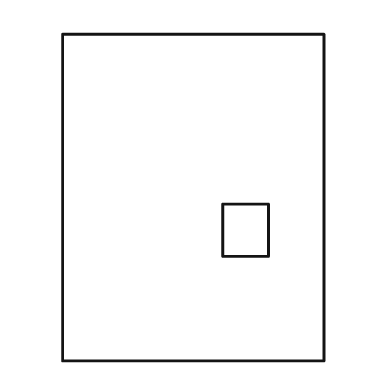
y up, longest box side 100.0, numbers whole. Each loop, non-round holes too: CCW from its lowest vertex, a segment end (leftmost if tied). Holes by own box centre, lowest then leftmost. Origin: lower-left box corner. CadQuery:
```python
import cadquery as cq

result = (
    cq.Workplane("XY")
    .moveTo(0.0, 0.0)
    .lineTo(80.0, 0.0)
    .lineTo(80.0, 100.0)
    .lineTo(0.0, 100.0)
    .close()
    .moveTo(49.0, 32.0)
    .lineTo(63.0, 32.0)
    .lineTo(63.0, 48.0)
    .lineTo(49.0, 48.0)
    .close()
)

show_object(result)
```